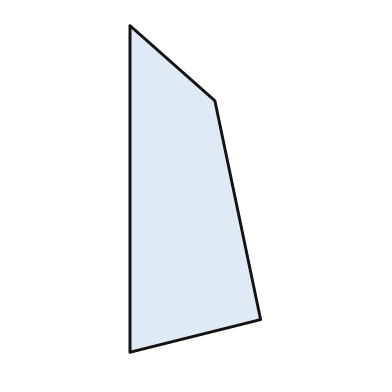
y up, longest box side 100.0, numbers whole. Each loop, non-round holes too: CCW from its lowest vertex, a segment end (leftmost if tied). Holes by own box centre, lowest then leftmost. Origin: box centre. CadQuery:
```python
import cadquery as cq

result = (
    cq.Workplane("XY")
    .moveTo(-20.0, -50.0)
    .lineTo(20.0, -40.0)
    .lineTo(6.0, 27.0)
    .lineTo(-20.0, 50.0)
    .close()
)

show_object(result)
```